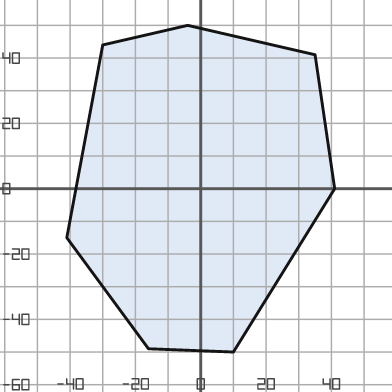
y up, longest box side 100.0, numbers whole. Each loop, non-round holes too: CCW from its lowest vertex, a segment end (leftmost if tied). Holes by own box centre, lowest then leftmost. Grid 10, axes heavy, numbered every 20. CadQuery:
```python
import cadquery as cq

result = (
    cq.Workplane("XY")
    .moveTo(10.0, -50.0)
    .lineTo(41.0, 0.0)
    .lineTo(35.0, 41.0)
    .lineTo(-4.0, 50.0)
    .lineTo(-30.0, 44.0)
    .lineTo(-41.0, -15.0)
    .lineTo(-16.0, -49.0)
    .close()
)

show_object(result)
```